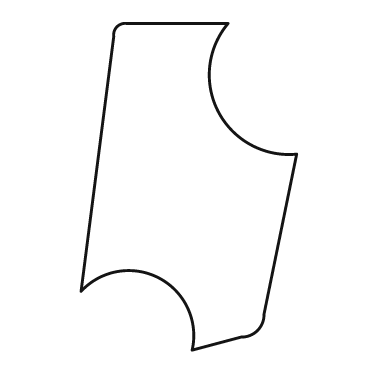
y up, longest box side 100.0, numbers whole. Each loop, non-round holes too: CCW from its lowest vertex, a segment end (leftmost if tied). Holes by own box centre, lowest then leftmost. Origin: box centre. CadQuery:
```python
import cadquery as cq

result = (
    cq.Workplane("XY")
    .moveTo(1.0, -50.0)
    .lineTo(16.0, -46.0)
    .threePointArc((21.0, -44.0), (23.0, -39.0))
    .lineTo(33.0, 10.0)
    .threePointArc((9.0, 23.0), (12.0, 50.0))
    .lineTo(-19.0, 50.0)
    .threePointArc((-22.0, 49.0), (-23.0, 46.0))
    .lineTo(-33.0, -32.0)
    .threePointArc((-9.0, -28.0), (1.0, -50.0))
    .close()
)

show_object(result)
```